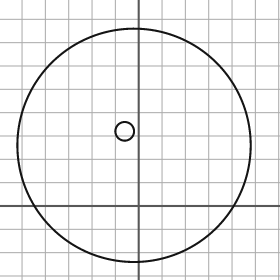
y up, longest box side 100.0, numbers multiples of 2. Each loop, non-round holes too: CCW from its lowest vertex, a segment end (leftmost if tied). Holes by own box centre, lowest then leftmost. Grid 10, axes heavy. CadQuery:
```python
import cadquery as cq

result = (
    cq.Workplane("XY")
    .moveTo(-2.0, 26.0)
    .circle(50.0)
    .moveTo(-6.0, 32.0)
    .circle(4.0)
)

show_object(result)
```